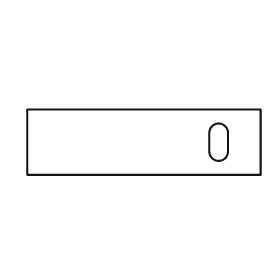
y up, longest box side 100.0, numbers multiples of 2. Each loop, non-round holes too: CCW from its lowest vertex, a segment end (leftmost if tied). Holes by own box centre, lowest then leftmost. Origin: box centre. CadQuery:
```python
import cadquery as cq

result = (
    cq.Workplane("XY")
    .moveTo(-50.0, -14.0)
    .lineTo(50.0, -14.0)
    .lineTo(50.0, 14.0)
    .lineTo(-50.0, 14.0)
    .close()
    .moveTo(28.0, -4.0)
    .threePointArc((32.0, -8.0), (36.0, -4.0))
    .lineTo(36.0, 4.0)
    .threePointArc((32.0, 8.0), (28.0, 4.0))
    .close()
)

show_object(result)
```